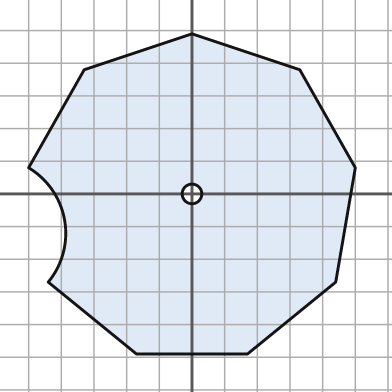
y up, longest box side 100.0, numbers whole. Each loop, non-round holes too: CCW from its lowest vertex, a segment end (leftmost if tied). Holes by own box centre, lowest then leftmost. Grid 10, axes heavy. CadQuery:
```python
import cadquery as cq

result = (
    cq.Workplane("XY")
    .moveTo(-17.0, -49.0)
    .lineTo(17.0, -49.0)
    .lineTo(44.0, -27.0)
    .lineTo(50.0, 8.0)
    .lineTo(33.0, 38.0)
    .lineTo(0.0, 49.0)
    .lineTo(-33.0, 38.0)
    .lineTo(-50.0, 8.0)
    .threePointArc((-39.0, -8.0), (-44.0, -27.0))
    .close()
    .moveTo(0.0, 0.0)
    .circle(3.0)
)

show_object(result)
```